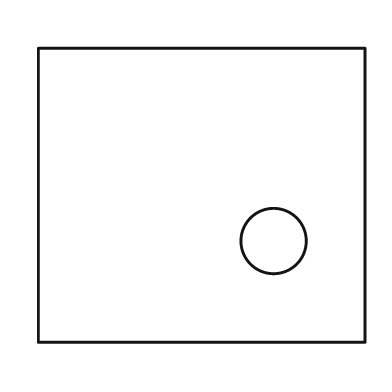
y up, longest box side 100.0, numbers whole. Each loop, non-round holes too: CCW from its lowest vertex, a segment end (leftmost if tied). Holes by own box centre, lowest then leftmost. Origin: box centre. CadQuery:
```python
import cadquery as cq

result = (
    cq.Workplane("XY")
    .moveTo(-50.0, -45.0)
    .lineTo(50.0, -45.0)
    .lineTo(50.0, 45.0)
    .lineTo(-50.0, 45.0)
    .close()
    .moveTo(22.0, -14.0)
    .circle(10.0)
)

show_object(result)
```